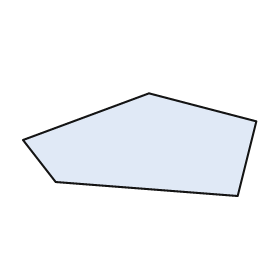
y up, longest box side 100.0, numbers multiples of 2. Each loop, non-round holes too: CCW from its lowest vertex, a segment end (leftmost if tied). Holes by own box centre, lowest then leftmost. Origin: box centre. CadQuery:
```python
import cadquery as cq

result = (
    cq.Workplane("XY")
    .moveTo(42.0, -22.0)
    .lineTo(50.0, 10.0)
    .lineTo(4.0, 22.0)
    .lineTo(-50.0, 2.0)
    .lineTo(-36.0, -16.0)
    .close()
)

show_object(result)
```